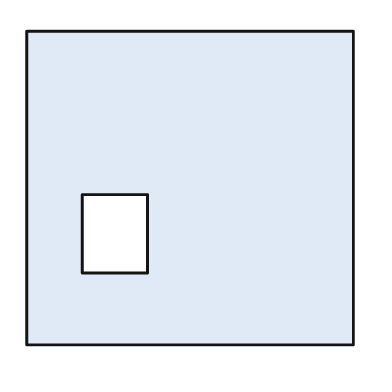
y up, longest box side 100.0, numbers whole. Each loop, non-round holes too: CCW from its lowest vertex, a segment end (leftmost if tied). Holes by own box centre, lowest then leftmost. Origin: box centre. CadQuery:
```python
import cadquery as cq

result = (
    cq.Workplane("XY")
    .moveTo(-50.0, -48.0)
    .lineTo(50.0, -48.0)
    .lineTo(50.0, 48.0)
    .lineTo(-50.0, 48.0)
    .close()
    .moveTo(-33.0, -26.0)
    .lineTo(-13.0, -26.0)
    .lineTo(-13.0, -2.0)
    .lineTo(-33.0, -2.0)
    .close()
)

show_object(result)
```